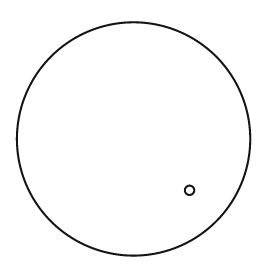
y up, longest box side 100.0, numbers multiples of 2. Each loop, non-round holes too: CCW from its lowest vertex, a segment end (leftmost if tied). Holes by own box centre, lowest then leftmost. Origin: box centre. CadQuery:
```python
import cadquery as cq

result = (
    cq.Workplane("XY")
    .moveTo(0.0, 0.0)
    .circle(50.0)
    .moveTo(24.0, -22.0)
    .circle(2.0)
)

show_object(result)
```